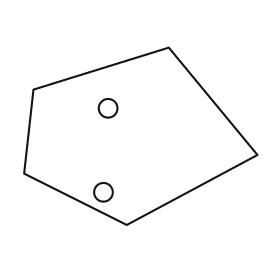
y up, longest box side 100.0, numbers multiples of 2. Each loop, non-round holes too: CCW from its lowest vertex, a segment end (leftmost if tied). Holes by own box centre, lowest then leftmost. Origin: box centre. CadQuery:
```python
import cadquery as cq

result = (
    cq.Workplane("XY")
    .moveTo(-6.0, -38.0)
    .lineTo(50.0, -8.0)
    .lineTo(12.0, 38.0)
    .lineTo(-46.0, 20.0)
    .lineTo(-50.0, -16.0)
    .close()
    .moveTo(-16.0, -24.0)
    .circle(4.0)
    .moveTo(-14.0, 12.0)
    .circle(4.0)
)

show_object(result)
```